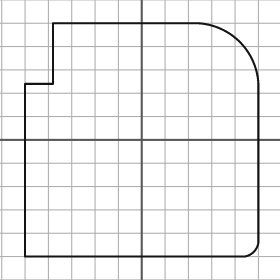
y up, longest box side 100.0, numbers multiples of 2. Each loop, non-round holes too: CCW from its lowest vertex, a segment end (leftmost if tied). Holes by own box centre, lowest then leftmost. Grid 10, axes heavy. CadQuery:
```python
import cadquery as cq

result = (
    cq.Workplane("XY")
    .moveTo(-50.0, -50.0)
    .lineTo(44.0, -50.0)
    .threePointArc((48.0, -48.0), (50.0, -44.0))
    .lineTo(50.0, 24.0)
    .threePointArc((42.0, 42.0), (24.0, 50.0))
    .lineTo(-38.0, 50.0)
    .lineTo(-38.0, 24.0)
    .lineTo(-50.0, 24.0)
    .close()
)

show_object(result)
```